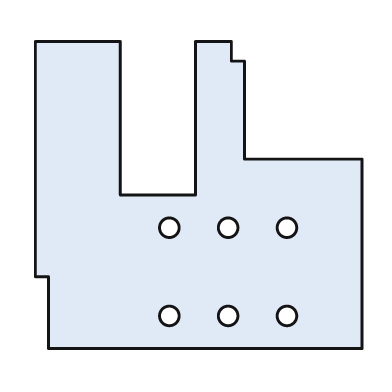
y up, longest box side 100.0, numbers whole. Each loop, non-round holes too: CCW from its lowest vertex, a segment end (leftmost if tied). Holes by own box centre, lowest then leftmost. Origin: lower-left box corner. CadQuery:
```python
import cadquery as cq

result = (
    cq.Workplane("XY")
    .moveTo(4.0, 0.0)
    .lineTo(100.0, 0.0)
    .lineTo(100.0, 58.0)
    .lineTo(64.0, 58.0)
    .lineTo(64.0, 88.0)
    .lineTo(60.0, 88.0)
    .lineTo(60.0, 94.0)
    .lineTo(49.0, 94.0)
    .lineTo(49.0, 47.0)
    .lineTo(26.0, 47.0)
    .lineTo(26.0, 94.0)
    .lineTo(0.0, 94.0)
    .lineTo(0.0, 22.0)
    .lineTo(4.0, 22.0)
    .close()
    .moveTo(41.0, 10.0)
    .circle(3.0)
    .moveTo(59.0, 10.0)
    .circle(3.0)
    .moveTo(77.0, 10.0)
    .circle(3.0)
    .moveTo(41.0, 37.0)
    .circle(3.0)
    .moveTo(59.0, 37.0)
    .circle(3.0)
    .moveTo(77.0, 37.0)
    .circle(3.0)
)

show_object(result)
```